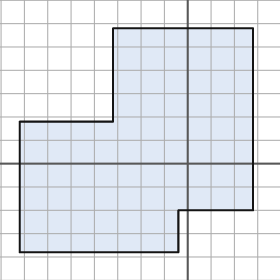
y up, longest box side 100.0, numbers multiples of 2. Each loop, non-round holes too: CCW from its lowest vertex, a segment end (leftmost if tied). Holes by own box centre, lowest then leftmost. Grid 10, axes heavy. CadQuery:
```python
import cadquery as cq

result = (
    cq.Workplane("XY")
    .moveTo(-72.0, -38.0)
    .lineTo(-4.0, -38.0)
    .lineTo(-4.0, -20.0)
    .lineTo(28.0, -20.0)
    .lineTo(28.0, 58.0)
    .lineTo(-32.0, 58.0)
    .lineTo(-32.0, 18.0)
    .lineTo(-72.0, 18.0)
    .close()
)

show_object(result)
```